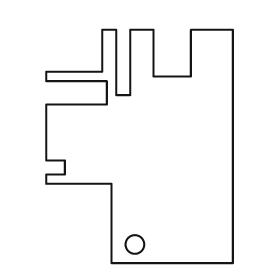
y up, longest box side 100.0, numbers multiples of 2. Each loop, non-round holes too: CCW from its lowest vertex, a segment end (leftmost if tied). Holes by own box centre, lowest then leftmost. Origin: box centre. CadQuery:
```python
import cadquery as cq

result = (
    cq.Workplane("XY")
    .moveTo(-12.0, -50.0)
    .lineTo(40.0, -50.0)
    .lineTo(40.0, 50.0)
    .lineTo(22.0, 50.0)
    .lineTo(22.0, 30.0)
    .lineTo(6.0, 30.0)
    .lineTo(6.0, 50.0)
    .lineTo(-4.0, 50.0)
    .lineTo(-4.0, 22.0)
    .lineTo(-10.0, 22.0)
    .lineTo(-10.0, 50.0)
    .lineTo(-16.0, 50.0)
    .lineTo(-16.0, 32.0)
    .lineTo(-40.0, 32.0)
    .lineTo(-40.0, 28.0)
    .lineTo(-14.0, 28.0)
    .lineTo(-14.0, 18.0)
    .lineTo(-40.0, 18.0)
    .lineTo(-40.0, -6.0)
    .lineTo(-32.0, -6.0)
    .lineTo(-32.0, -12.0)
    .lineTo(-40.0, -12.0)
    .lineTo(-40.0, -16.0)
    .lineTo(-12.0, -16.0)
    .close()
    .moveTo(-2.0, -42.0)
    .circle(4.0)
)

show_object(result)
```